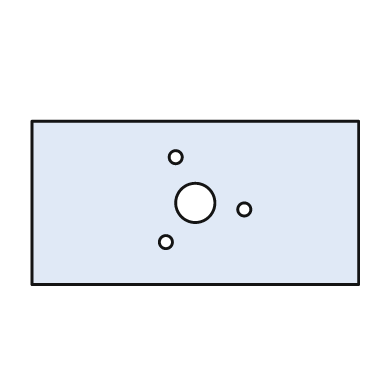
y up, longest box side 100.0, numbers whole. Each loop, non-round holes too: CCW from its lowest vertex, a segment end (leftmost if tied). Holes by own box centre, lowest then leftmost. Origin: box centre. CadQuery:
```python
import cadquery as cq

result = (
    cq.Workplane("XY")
    .moveTo(-50.0, -25.0)
    .lineTo(50.0, -25.0)
    .lineTo(50.0, 25.0)
    .lineTo(-50.0, 25.0)
    .close()
    .moveTo(-9.0, -12.0)
    .circle(2.0)
    .moveTo(15.0, -2.0)
    .circle(2.0)
    .moveTo(0.0, 0.0)
    .circle(6.0)
    .moveTo(-6.0, 14.0)
    .circle(2.0)
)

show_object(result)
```